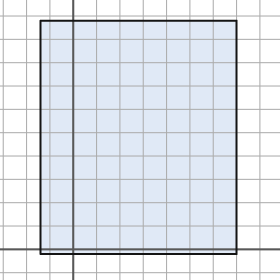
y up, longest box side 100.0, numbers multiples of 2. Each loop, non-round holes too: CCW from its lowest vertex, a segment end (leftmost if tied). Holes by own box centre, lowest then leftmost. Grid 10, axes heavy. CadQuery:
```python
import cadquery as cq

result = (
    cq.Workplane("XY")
    .moveTo(-14.0, -2.0)
    .lineTo(70.0, -2.0)
    .lineTo(70.0, 98.0)
    .lineTo(-14.0, 98.0)
    .close()
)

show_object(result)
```